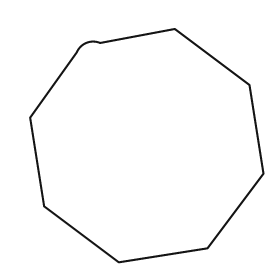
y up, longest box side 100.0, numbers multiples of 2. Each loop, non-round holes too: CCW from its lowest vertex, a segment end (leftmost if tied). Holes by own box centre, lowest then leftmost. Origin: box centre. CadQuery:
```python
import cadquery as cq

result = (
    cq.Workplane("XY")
    .moveTo(-12.0, -50.0)
    .lineTo(26.0, -44.0)
    .lineTo(50.0, -12.0)
    .lineTo(44.0, 26.0)
    .lineTo(12.0, 50.0)
    .lineTo(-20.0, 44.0)
    .threePointArc((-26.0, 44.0), (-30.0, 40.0))
    .lineTo(-50.0, 12.0)
    .lineTo(-44.0, -26.0)
    .close()
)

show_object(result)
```